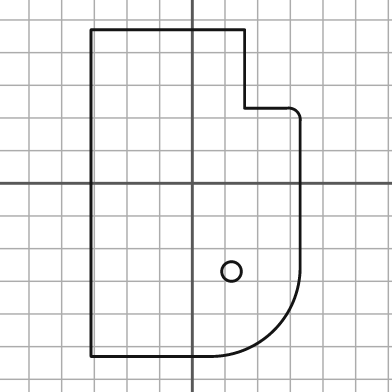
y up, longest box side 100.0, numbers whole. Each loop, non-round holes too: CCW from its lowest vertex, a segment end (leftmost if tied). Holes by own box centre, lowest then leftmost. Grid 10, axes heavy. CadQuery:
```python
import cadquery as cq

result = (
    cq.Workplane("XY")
    .moveTo(-31.0, -53.0)
    .lineTo(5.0, -53.0)
    .threePointArc((25.0, -45.0), (33.0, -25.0))
    .lineTo(33.0, 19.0)
    .threePointArc((32.0, 22.0), (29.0, 23.0))
    .lineTo(16.0, 23.0)
    .lineTo(16.0, 47.0)
    .lineTo(-31.0, 47.0)
    .close()
    .moveTo(12.0, -27.0)
    .circle(3.0)
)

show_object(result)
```